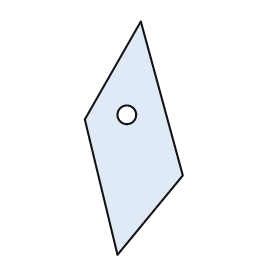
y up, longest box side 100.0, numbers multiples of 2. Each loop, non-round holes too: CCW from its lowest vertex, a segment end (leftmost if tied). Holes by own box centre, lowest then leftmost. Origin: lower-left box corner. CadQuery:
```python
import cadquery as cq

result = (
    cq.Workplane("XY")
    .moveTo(14.0, 0.0)
    .lineTo(42.0, 34.0)
    .lineTo(24.0, 100.0)
    .lineTo(0.0, 58.0)
    .close()
    .moveTo(18.0, 60.0)
    .circle(4.0)
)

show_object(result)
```